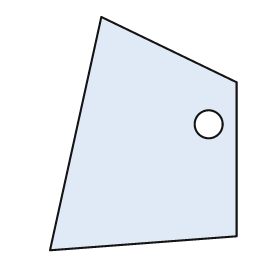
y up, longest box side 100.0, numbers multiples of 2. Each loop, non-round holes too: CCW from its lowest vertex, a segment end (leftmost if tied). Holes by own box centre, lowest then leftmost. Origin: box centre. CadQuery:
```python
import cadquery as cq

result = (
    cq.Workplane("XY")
    .moveTo(-40.0, -50.0)
    .lineTo(40.0, -44.0)
    .lineTo(40.0, 22.0)
    .lineTo(-18.0, 50.0)
    .close()
    .moveTo(28.0, 4.0)
    .circle(6.0)
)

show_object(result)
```